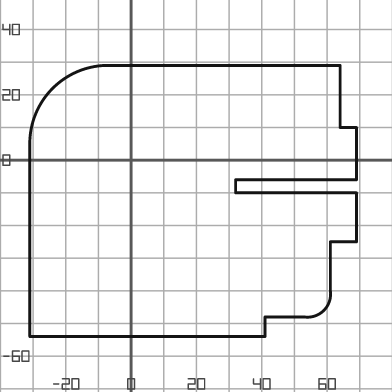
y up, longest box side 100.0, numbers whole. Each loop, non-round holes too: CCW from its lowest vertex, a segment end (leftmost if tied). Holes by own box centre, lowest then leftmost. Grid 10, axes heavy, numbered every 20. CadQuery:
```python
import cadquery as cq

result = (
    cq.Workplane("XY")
    .moveTo(-31.0, -54.0)
    .lineTo(41.0, -54.0)
    .lineTo(41.0, -48.0)
    .lineTo(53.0, -48.0)
    .threePointArc((59.0, -46.0), (61.0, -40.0))
    .lineTo(61.0, -25.0)
    .lineTo(69.0, -25.0)
    .lineTo(69.0, -10.0)
    .lineTo(32.0, -10.0)
    .lineTo(32.0, -6.0)
    .lineTo(69.0, -6.0)
    .lineTo(69.0, 10.0)
    .lineTo(64.0, 10.0)
    .lineTo(64.0, 29.0)
    .lineTo(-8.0, 29.0)
    .threePointArc((-24.0, 22.0), (-31.0, 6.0))
    .close()
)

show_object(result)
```